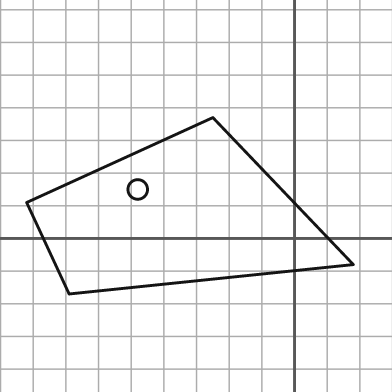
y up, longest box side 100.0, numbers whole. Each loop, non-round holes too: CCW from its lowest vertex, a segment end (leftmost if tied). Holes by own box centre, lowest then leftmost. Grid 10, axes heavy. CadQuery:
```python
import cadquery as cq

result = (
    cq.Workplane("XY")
    .moveTo(-69.0, -17.0)
    .lineTo(18.0, -8.0)
    .lineTo(-25.0, 37.0)
    .lineTo(-82.0, 11.0)
    .close()
    .moveTo(-48.0, 15.0)
    .circle(3.0)
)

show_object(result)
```